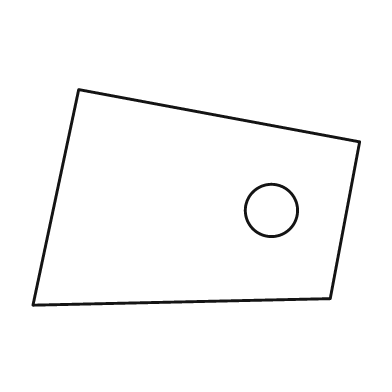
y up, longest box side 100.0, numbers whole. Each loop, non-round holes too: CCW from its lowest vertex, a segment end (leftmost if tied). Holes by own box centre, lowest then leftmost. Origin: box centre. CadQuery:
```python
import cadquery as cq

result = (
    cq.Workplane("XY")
    .moveTo(-50.0, -33.0)
    .lineTo(41.0, -31.0)
    .lineTo(50.0, 17.0)
    .lineTo(-36.0, 33.0)
    .close()
    .moveTo(23.0, -4.0)
    .circle(8.0)
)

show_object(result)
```